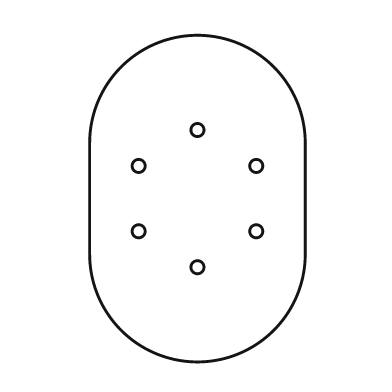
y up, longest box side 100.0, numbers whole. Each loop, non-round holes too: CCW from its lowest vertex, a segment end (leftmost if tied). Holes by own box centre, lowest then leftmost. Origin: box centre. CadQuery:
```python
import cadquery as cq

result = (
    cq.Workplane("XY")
    .moveTo(-33.0, -17.0)
    .threePointArc((0.0, -50.0), (33.0, -17.0))
    .lineTo(33.0, 17.0)
    .threePointArc((0.0, 50.0), (-33.0, 17.0))
    .close()
    .moveTo(0.0, -21.0)
    .circle(2.0)
    .moveTo(-18.0, -10.0)
    .circle(2.0)
    .moveTo(18.0, -10.0)
    .circle(2.0)
    .moveTo(-18.0, 10.0)
    .circle(2.0)
    .moveTo(18.0, 10.0)
    .circle(2.0)
    .moveTo(0.0, 21.0)
    .circle(2.0)
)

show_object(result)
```